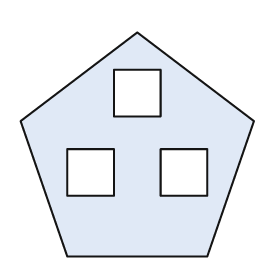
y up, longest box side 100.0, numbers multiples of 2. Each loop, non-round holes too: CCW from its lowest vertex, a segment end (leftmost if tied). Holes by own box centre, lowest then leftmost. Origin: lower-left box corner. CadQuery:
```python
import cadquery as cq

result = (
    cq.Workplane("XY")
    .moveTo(20.0, 0.0)
    .lineTo(80.0, 0.0)
    .lineTo(100.0, 58.0)
    .lineTo(50.0, 96.0)
    .lineTo(0.0, 58.0)
    .close()
    .moveTo(20.0, 26.0)
    .lineTo(40.0, 26.0)
    .lineTo(40.0, 46.0)
    .lineTo(20.0, 46.0)
    .close()
    .moveTo(60.0, 26.0)
    .lineTo(80.0, 26.0)
    .lineTo(80.0, 46.0)
    .lineTo(60.0, 46.0)
    .close()
    .moveTo(40.0, 60.0)
    .lineTo(60.0, 60.0)
    .lineTo(60.0, 80.0)
    .lineTo(40.0, 80.0)
    .close()
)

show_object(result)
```